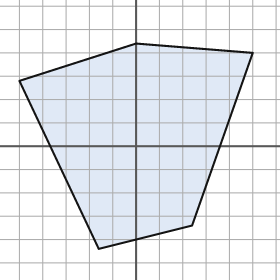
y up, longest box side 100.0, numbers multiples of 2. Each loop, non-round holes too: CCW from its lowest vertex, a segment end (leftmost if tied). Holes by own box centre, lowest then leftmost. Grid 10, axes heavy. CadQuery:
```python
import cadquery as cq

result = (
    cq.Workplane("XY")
    .moveTo(-16.0, -44.0)
    .lineTo(24.0, -34.0)
    .lineTo(50.0, 40.0)
    .lineTo(0.0, 44.0)
    .lineTo(-50.0, 28.0)
    .close()
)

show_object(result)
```